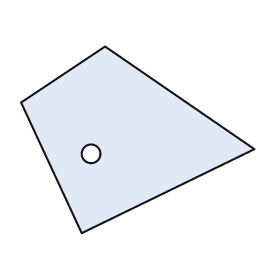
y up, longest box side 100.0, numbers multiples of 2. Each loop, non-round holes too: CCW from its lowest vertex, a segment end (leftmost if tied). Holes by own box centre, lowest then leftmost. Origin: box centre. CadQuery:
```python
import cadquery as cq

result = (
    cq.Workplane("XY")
    .moveTo(-24.0, -40.0)
    .lineTo(50.0, -4.0)
    .lineTo(-14.0, 40.0)
    .lineTo(-50.0, 16.0)
    .close()
    .moveTo(-20.0, -6.0)
    .circle(4.0)
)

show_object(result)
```